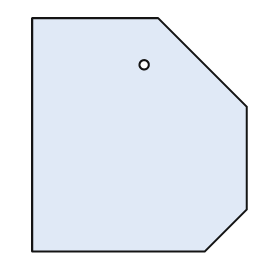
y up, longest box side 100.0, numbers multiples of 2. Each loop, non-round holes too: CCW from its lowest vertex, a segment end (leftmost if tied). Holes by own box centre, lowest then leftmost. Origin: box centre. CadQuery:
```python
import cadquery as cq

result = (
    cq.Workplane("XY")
    .moveTo(-46.0, -50.0)
    .lineTo(28.0, -50.0)
    .lineTo(46.0, -32.0)
    .lineTo(46.0, 12.0)
    .lineTo(8.0, 50.0)
    .lineTo(-46.0, 50.0)
    .close()
    .moveTo(2.0, 30.0)
    .circle(2.0)
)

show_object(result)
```